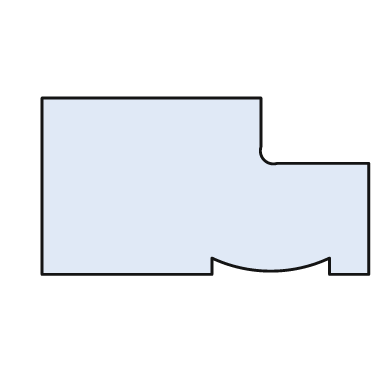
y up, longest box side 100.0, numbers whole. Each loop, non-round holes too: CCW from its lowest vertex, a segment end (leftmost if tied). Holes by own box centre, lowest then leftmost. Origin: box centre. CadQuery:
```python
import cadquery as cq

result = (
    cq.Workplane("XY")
    .moveTo(-50.0, -27.0)
    .lineTo(2.0, -27.0)
    .lineTo(2.0, -22.0)
    .threePointArc((20.0, -26.0), (38.0, -22.0))
    .lineTo(38.0, -27.0)
    .lineTo(50.0, -27.0)
    .lineTo(50.0, 7.0)
    .lineTo(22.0, 7.0)
    .threePointArc((18.0, 8.0), (17.0, 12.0))
    .lineTo(17.0, 27.0)
    .lineTo(-50.0, 27.0)
    .close()
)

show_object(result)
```